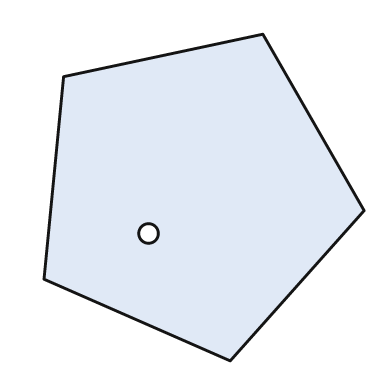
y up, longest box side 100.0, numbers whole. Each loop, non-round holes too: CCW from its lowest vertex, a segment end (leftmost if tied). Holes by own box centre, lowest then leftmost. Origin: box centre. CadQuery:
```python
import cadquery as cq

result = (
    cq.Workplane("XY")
    .moveTo(8.0, -50.0)
    .lineTo(49.0, -4.0)
    .lineTo(18.0, 50.0)
    .lineTo(-43.0, 37.0)
    .lineTo(-49.0, -25.0)
    .close()
    .moveTo(-17.0, -11.0)
    .circle(3.0)
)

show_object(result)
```